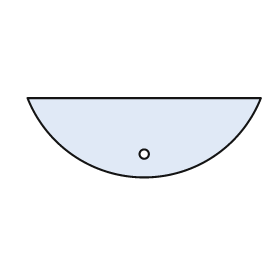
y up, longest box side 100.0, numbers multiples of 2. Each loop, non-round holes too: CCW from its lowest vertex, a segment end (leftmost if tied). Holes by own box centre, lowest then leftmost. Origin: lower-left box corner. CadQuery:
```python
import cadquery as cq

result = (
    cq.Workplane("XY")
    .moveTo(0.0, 34.0)
    .threePointArc((50.0, 0.0), (100.0, 34.0))
    .close()
    .moveTo(50.0, 10.0)
    .circle(2.0)
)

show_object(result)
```